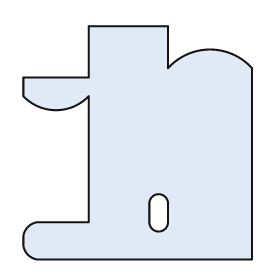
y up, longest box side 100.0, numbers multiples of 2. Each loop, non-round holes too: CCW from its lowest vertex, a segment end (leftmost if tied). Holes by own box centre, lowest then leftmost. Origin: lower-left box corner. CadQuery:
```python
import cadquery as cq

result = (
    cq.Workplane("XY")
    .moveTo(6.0, 0.0)
    .lineTo(98.0, 0.0)
    .lineTo(98.0, 82.0)
    .threePointArc((80.0, 90.0), (62.0, 82.0))
    .lineTo(62.0, 100.0)
    .lineTo(28.0, 100.0)
    .lineTo(28.0, 78.0)
    .lineTo(0.0, 78.0)
    .lineTo(0.0, 70.0)
    .threePointArc((14.0, 64.0), (28.0, 70.0))
    .lineTo(28.0, 16.0)
    .lineTo(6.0, 16.0)
    .threePointArc((2.0, 14.0), (0.0, 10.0))
    .lineTo(0.0, 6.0)
    .threePointArc((2.0, 2.0), (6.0, 0.0))
    .close()
    .moveTo(54.0, 16.0)
    .threePointArc((58.0, 12.0), (62.0, 16.0))
    .lineTo(62.0, 24.0)
    .threePointArc((58.0, 28.0), (54.0, 24.0))
    .close()
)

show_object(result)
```